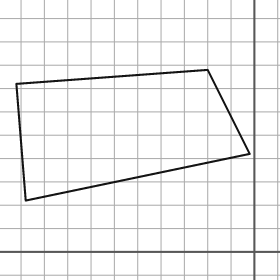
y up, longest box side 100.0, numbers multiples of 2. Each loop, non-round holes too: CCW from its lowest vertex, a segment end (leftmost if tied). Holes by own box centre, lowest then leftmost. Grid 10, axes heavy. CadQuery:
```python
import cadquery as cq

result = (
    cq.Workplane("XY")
    .moveTo(-98.0, 22.0)
    .lineTo(-2.0, 42.0)
    .lineTo(-20.0, 78.0)
    .lineTo(-102.0, 72.0)
    .close()
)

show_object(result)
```